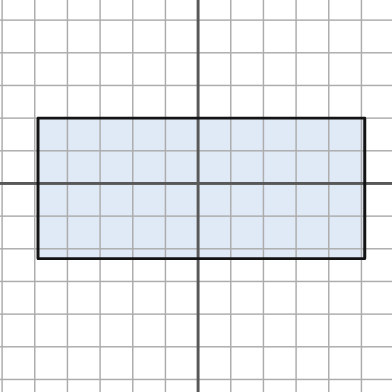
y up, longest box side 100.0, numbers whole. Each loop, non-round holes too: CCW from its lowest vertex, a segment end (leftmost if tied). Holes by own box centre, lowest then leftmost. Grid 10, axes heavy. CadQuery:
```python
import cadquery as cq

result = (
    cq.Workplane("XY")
    .moveTo(-49.0, -23.0)
    .lineTo(51.0, -23.0)
    .lineTo(51.0, 20.0)
    .lineTo(-49.0, 20.0)
    .close()
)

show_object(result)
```